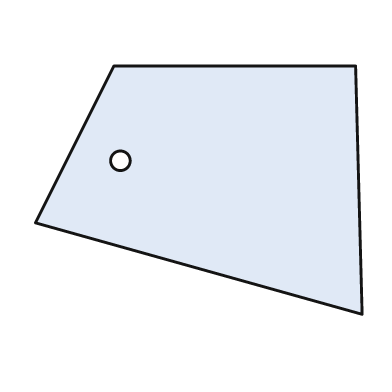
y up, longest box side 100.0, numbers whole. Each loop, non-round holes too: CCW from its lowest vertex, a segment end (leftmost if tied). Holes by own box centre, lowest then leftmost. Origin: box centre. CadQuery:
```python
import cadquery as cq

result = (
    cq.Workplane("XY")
    .moveTo(50.0, -38.0)
    .lineTo(48.0, 38.0)
    .lineTo(-26.0, 38.0)
    .lineTo(-50.0, -10.0)
    .close()
    .moveTo(-24.0, 9.0)
    .circle(3.0)
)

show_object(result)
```